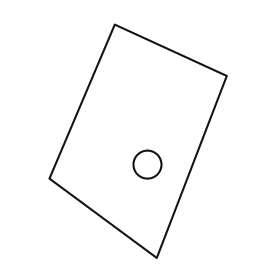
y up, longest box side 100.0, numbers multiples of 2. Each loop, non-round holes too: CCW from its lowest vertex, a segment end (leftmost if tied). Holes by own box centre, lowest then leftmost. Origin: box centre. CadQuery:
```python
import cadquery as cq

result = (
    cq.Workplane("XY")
    .moveTo(8.0, -50.0)
    .lineTo(38.0, 28.0)
    .lineTo(-10.0, 50.0)
    .lineTo(-38.0, -16.0)
    .close()
    .moveTo(4.0, -10.0)
    .circle(6.0)
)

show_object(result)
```